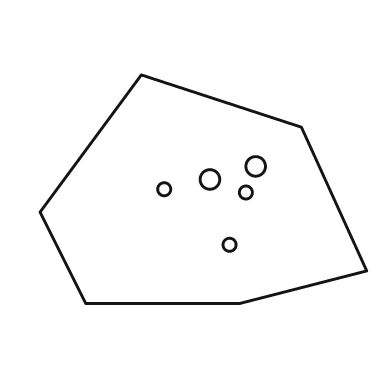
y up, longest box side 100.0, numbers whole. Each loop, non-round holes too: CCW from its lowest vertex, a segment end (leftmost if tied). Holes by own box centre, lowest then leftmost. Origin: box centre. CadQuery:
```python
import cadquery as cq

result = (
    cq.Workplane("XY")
    .moveTo(-36.0, -35.0)
    .lineTo(11.0, -35.0)
    .lineTo(50.0, -25.0)
    .lineTo(30.0, 19.0)
    .lineTo(-19.0, 35.0)
    .lineTo(-50.0, -7.0)
    .close()
    .moveTo(8.0, -17.0)
    .circle(2.0)
    .moveTo(13.0, -1.0)
    .circle(2.0)
    .moveTo(-12.0, 0.0)
    .circle(2.0)
    .moveTo(2.0, 3.0)
    .circle(3.0)
    .moveTo(16.0, 7.0)
    .circle(3.0)
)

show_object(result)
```